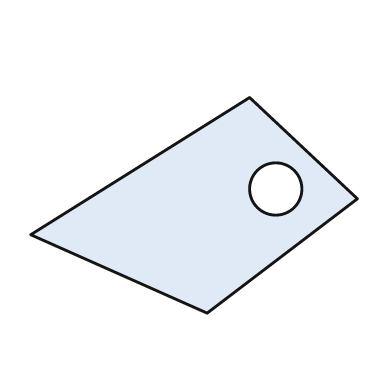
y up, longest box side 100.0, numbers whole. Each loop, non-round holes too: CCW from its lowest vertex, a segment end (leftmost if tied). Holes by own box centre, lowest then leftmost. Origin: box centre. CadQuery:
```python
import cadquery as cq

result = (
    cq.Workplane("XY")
    .moveTo(4.0, -33.0)
    .lineTo(50.0, 2.0)
    .lineTo(17.0, 33.0)
    .lineTo(-50.0, -9.0)
    .close()
    .moveTo(25.0, 5.0)
    .circle(8.0)
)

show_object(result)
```